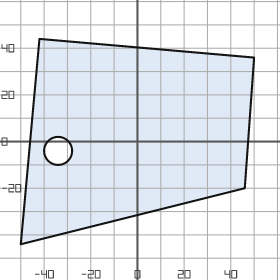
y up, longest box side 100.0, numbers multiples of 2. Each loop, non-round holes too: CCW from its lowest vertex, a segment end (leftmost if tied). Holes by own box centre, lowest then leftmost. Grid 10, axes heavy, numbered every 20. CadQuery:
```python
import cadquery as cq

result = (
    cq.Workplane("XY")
    .moveTo(-50.0, -44.0)
    .lineTo(46.0, -20.0)
    .lineTo(50.0, 36.0)
    .lineTo(-42.0, 44.0)
    .close()
    .moveTo(-34.0, -4.0)
    .circle(6.0)
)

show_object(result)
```